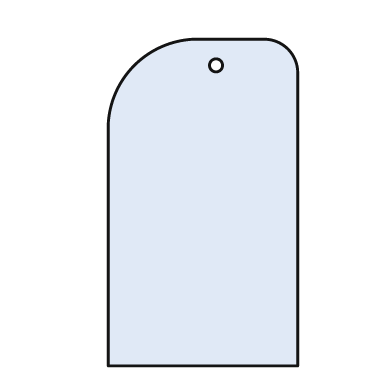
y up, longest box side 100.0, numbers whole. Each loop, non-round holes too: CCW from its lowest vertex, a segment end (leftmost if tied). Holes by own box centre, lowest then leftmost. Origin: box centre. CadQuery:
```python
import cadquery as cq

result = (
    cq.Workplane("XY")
    .moveTo(-29.0, -50.0)
    .lineTo(29.0, -50.0)
    .lineTo(29.0, 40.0)
    .threePointArc((26.0, 47.0), (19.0, 50.0))
    .lineTo(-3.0, 50.0)
    .threePointArc((-21.0, 42.0), (-29.0, 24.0))
    .close()
    .moveTo(4.0, 42.0)
    .circle(2.0)
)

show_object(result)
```